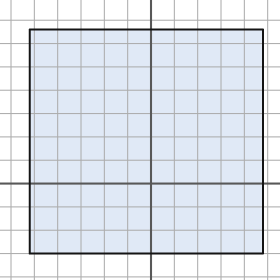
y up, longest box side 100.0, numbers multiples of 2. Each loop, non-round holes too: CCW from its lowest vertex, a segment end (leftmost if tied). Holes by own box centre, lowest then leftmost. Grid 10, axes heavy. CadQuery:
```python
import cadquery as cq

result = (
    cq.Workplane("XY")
    .moveTo(-52.0, -30.0)
    .lineTo(48.0, -30.0)
    .lineTo(48.0, 66.0)
    .lineTo(-52.0, 66.0)
    .close()
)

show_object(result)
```